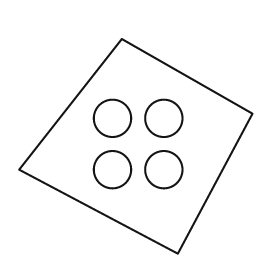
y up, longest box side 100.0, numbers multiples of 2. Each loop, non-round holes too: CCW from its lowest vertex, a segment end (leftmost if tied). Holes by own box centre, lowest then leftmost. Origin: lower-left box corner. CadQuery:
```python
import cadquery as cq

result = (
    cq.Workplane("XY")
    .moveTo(68.0, 0.0)
    .lineTo(100.0, 60.0)
    .lineTo(44.0, 92.0)
    .lineTo(0.0, 36.0)
    .close()
    .moveTo(40.0, 36.0)
    .circle(8.0)
    .moveTo(62.0, 36.0)
    .circle(8.0)
    .moveTo(40.0, 58.0)
    .circle(8.0)
    .moveTo(62.0, 58.0)
    .circle(8.0)
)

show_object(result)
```